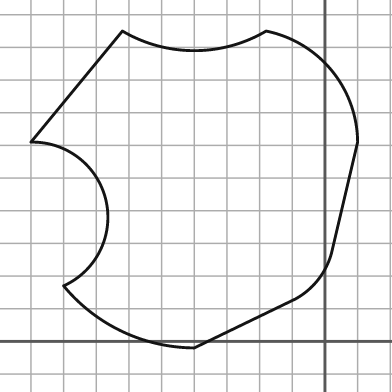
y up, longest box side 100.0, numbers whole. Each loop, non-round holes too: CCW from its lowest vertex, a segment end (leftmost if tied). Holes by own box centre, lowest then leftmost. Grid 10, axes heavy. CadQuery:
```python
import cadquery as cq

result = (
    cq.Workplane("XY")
    .moveTo(-40.0, -2.0)
    .lineTo(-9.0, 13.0)
    .threePointArc((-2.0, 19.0), (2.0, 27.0))
    .lineTo(10.0, 61.0)
    .threePointArc((2.0, 83.0), (-18.0, 95.0))
    .threePointArc((-40.0, 89.0), (-62.0, 95.0))
    .lineTo(-90.0, 61.0)
    .threePointArc((-67.0, 43.0), (-80.0, 17.0))
    .threePointArc((-62.0, 3.0), (-40.0, -2.0))
    .close()
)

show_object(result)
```